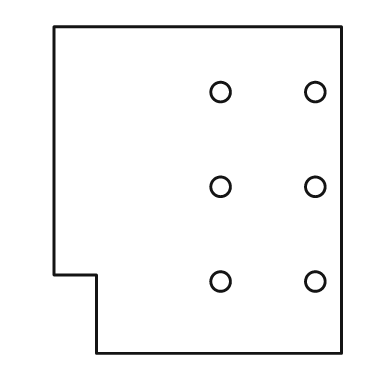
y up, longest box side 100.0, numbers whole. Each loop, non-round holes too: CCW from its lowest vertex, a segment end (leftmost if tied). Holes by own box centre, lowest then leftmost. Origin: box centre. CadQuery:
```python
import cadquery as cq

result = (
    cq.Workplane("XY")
    .moveTo(-31.0, -50.0)
    .lineTo(44.0, -50.0)
    .lineTo(44.0, 50.0)
    .lineTo(-44.0, 50.0)
    .lineTo(-44.0, -26.0)
    .lineTo(-31.0, -26.0)
    .close()
    .moveTo(7.0, -28.0)
    .circle(3.0)
    .moveTo(36.0, -28.0)
    .circle(3.0)
    .moveTo(7.0, 1.0)
    .circle(3.0)
    .moveTo(36.0, 1.0)
    .circle(3.0)
    .moveTo(7.0, 30.0)
    .circle(3.0)
    .moveTo(36.0, 30.0)
    .circle(3.0)
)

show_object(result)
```